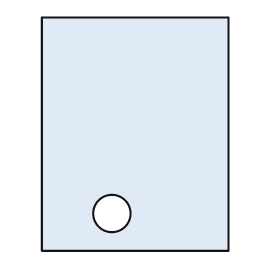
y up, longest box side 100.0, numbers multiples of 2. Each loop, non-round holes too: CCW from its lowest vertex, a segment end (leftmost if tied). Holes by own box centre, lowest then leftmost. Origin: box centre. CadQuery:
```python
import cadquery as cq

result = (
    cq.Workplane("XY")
    .moveTo(-40.0, -50.0)
    .lineTo(40.0, -50.0)
    .lineTo(40.0, 50.0)
    .lineTo(-40.0, 50.0)
    .close()
    .moveTo(-10.0, -34.0)
    .circle(8.0)
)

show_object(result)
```